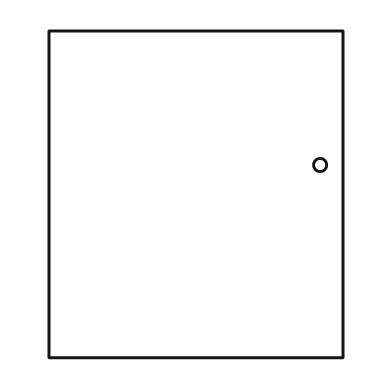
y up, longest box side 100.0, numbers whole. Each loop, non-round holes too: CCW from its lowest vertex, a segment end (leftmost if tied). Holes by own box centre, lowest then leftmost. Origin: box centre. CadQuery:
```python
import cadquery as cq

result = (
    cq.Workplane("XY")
    .moveTo(-45.0, -50.0)
    .lineTo(45.0, -50.0)
    .lineTo(45.0, 50.0)
    .lineTo(-45.0, 50.0)
    .close()
    .moveTo(38.0, 9.0)
    .circle(2.0)
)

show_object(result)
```